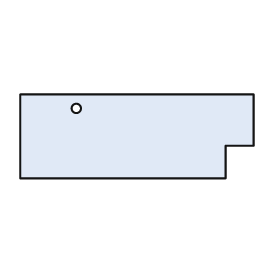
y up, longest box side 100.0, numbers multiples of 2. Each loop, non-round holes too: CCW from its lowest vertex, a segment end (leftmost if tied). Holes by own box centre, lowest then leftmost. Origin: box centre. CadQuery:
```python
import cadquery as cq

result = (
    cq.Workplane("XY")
    .moveTo(-50.0, -18.0)
    .lineTo(38.0, -18.0)
    .lineTo(38.0, -4.0)
    .lineTo(50.0, -4.0)
    .lineTo(50.0, 18.0)
    .lineTo(-50.0, 18.0)
    .close()
    .moveTo(-26.0, 12.0)
    .circle(2.0)
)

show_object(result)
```